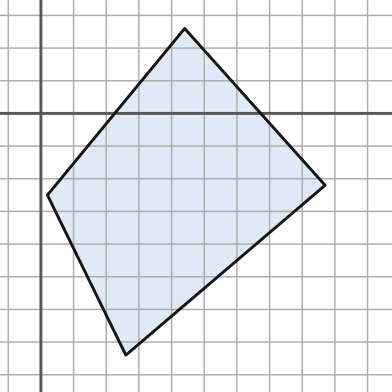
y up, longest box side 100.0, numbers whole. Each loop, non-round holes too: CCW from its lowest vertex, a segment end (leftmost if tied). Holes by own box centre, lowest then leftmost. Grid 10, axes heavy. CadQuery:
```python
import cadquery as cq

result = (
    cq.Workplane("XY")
    .moveTo(26.0, -74.0)
    .lineTo(87.0, -22.0)
    .lineTo(44.0, 26.0)
    .lineTo(2.0, -25.0)
    .close()
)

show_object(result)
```